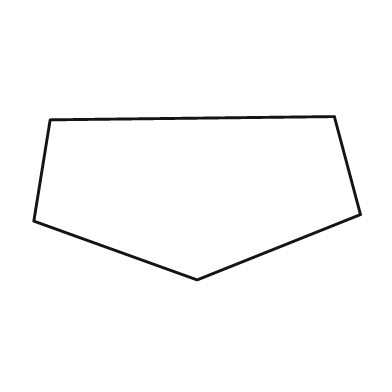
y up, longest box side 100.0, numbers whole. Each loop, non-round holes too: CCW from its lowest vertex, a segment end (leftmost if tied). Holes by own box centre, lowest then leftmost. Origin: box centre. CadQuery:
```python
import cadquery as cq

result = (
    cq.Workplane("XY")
    .moveTo(0.0, -25.0)
    .lineTo(50.0, -5.0)
    .lineTo(42.0, 25.0)
    .lineTo(-45.0, 24.0)
    .lineTo(-50.0, -7.0)
    .close()
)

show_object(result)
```